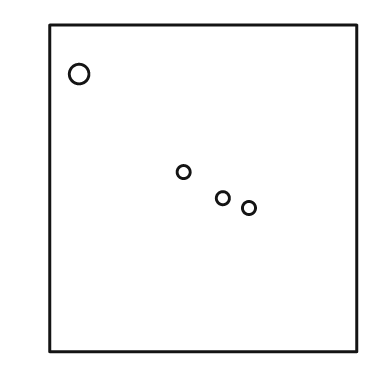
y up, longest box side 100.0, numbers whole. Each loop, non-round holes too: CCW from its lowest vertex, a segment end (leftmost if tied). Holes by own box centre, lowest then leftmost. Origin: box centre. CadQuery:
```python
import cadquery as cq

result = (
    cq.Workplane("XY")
    .moveTo(-47.0, -50.0)
    .lineTo(47.0, -50.0)
    .lineTo(47.0, 50.0)
    .lineTo(-47.0, 50.0)
    .close()
    .moveTo(14.0, -6.0)
    .circle(2.0)
    .moveTo(6.0, -3.0)
    .circle(2.0)
    .moveTo(-6.0, 5.0)
    .circle(2.0)
    .moveTo(-38.0, 35.0)
    .circle(3.0)
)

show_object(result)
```